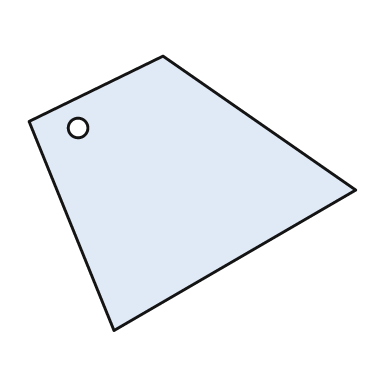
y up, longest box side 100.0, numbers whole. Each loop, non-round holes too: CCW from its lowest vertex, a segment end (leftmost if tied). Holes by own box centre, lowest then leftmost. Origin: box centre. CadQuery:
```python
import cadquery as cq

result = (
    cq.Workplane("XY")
    .moveTo(-24.0, -42.0)
    .lineTo(50.0, 1.0)
    .lineTo(-9.0, 42.0)
    .lineTo(-50.0, 22.0)
    .close()
    .moveTo(-35.0, 20.0)
    .circle(3.0)
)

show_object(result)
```